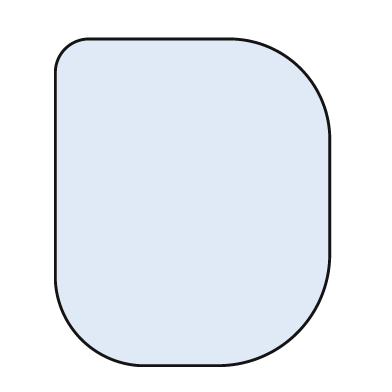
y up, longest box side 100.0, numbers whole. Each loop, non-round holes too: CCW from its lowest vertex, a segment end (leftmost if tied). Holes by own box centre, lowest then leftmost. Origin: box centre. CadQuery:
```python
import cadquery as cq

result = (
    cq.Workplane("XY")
    .moveTo(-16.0, -50.0)
    .lineTo(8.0, -50.0)
    .threePointArc((32.0, -40.0), (42.0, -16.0))
    .lineTo(42.0, 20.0)
    .threePointArc((33.0, 41.0), (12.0, 50.0))
    .lineTo(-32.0, 50.0)
    .threePointArc((-39.0, 47.0), (-42.0, 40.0))
    .lineTo(-42.0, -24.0)
    .threePointArc((-34.0, -42.0), (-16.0, -50.0))
    .close()
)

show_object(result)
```